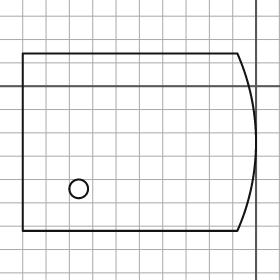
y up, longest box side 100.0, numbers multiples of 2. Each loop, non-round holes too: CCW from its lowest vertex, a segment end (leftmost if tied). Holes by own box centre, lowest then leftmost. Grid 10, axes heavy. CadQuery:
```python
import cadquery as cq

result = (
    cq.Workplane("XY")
    .moveTo(-100.0, -62.0)
    .lineTo(-8.0, -62.0)
    .threePointArc((0.0, -24.0), (-8.0, 14.0))
    .lineTo(-100.0, 14.0)
    .close()
    .moveTo(-76.0, -44.0)
    .circle(4.0)
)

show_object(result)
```